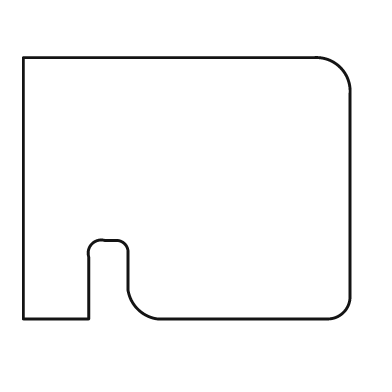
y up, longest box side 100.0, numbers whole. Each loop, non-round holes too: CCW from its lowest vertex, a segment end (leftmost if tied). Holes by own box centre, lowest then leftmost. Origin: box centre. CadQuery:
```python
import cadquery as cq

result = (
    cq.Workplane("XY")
    .moveTo(-50.0, -40.0)
    .lineTo(-30.0, -40.0)
    .lineTo(-30.0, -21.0)
    .threePointArc((-29.0, -17.0), (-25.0, -16.0))
    .lineTo(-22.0, -16.0)
    .threePointArc((-19.0, -17.0), (-18.0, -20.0))
    .lineTo(-18.0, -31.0)
    .threePointArc((-15.0, -37.0), (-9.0, -40.0))
    .lineTo(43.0, -40.0)
    .threePointArc((48.0, -38.0), (50.0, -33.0))
    .lineTo(50.0, 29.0)
    .threePointArc((47.0, 37.0), (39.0, 40.0))
    .lineTo(-50.0, 40.0)
    .close()
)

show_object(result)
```